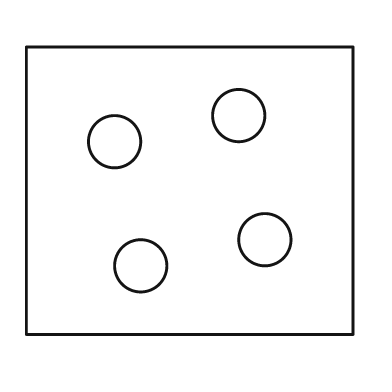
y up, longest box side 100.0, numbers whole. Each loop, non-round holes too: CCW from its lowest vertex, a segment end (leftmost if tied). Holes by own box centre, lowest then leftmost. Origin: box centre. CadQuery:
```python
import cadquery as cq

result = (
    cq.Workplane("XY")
    .moveTo(-50.0, -44.0)
    .lineTo(50.0, -44.0)
    .lineTo(50.0, 44.0)
    .lineTo(-50.0, 44.0)
    .close()
    .moveTo(-15.0, -23.0)
    .circle(8.0)
    .moveTo(23.0, -15.0)
    .circle(8.0)
    .moveTo(-23.0, 15.0)
    .circle(8.0)
    .moveTo(15.0, 23.0)
    .circle(8.0)
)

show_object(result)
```